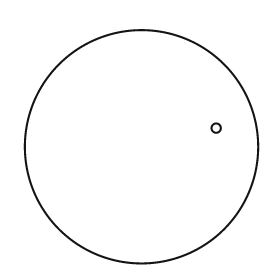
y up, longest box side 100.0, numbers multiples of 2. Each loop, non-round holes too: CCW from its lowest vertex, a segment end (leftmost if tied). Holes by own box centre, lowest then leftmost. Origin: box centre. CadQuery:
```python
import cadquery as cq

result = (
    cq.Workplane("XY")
    .moveTo(0.0, 0.0)
    .circle(50.0)
    .moveTo(32.0, 8.0)
    .circle(2.0)
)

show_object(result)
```